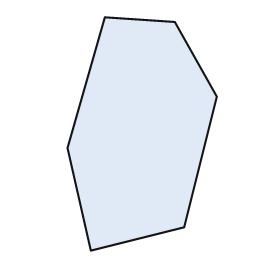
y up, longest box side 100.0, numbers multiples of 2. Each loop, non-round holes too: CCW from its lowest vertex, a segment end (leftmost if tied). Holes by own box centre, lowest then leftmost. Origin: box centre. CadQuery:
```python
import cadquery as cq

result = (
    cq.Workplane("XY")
    .moveTo(-22.0, -50.0)
    .lineTo(18.0, -40.0)
    .lineTo(32.0, 16.0)
    .lineTo(14.0, 48.0)
    .lineTo(-16.0, 50.0)
    .lineTo(-32.0, -6.0)
    .close()
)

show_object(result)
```